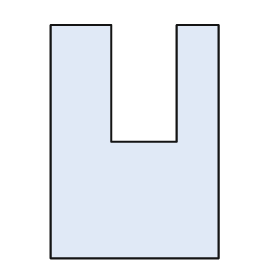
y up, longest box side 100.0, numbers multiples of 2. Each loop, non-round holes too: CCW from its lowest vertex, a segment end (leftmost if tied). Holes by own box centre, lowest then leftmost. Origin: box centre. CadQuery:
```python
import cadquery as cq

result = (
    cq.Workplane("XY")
    .moveTo(-36.0, -50.0)
    .lineTo(36.0, -50.0)
    .lineTo(36.0, 50.0)
    .lineTo(18.0, 50.0)
    .lineTo(18.0, 0.0)
    .lineTo(-10.0, 0.0)
    .lineTo(-10.0, 50.0)
    .lineTo(-36.0, 50.0)
    .close()
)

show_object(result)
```